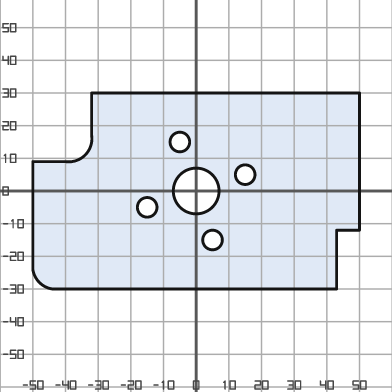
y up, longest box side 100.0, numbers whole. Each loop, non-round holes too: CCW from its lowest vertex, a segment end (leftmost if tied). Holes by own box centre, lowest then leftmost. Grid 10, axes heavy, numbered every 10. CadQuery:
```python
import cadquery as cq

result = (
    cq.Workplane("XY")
    .moveTo(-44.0, -30.0)
    .lineTo(43.0, -30.0)
    .lineTo(43.0, -12.0)
    .lineTo(50.0, -12.0)
    .lineTo(50.0, 30.0)
    .lineTo(-32.0, 30.0)
    .lineTo(-32.0, 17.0)
    .threePointArc((-34.0, 11.0), (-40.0, 9.0))
    .lineTo(-50.0, 9.0)
    .lineTo(-50.0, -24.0)
    .threePointArc((-48.0, -28.0), (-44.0, -30.0))
    .close()
    .moveTo(5.0, -15.0)
    .circle(3.0)
    .moveTo(-15.0, -5.0)
    .circle(3.0)
    .moveTo(0.0, 0.0)
    .circle(7.0)
    .moveTo(15.0, 5.0)
    .circle(3.0)
    .moveTo(-5.0, 15.0)
    .circle(3.0)
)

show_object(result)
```